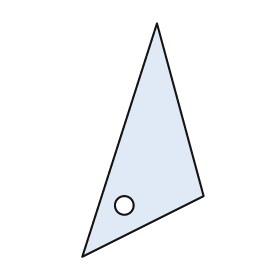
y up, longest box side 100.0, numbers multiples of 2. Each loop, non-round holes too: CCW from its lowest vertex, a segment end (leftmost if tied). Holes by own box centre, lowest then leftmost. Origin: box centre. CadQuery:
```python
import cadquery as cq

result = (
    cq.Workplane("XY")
    .moveTo(-26.0, -50.0)
    .lineTo(26.0, -24.0)
    .lineTo(6.0, 50.0)
    .close()
    .moveTo(-8.0, -28.0)
    .circle(4.0)
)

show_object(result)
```